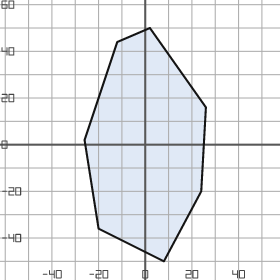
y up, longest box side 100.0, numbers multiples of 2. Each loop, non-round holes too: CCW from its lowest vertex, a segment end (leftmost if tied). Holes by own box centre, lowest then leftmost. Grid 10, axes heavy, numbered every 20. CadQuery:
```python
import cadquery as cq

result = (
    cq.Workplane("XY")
    .moveTo(8.0, -50.0)
    .lineTo(24.0, -20.0)
    .lineTo(26.0, 16.0)
    .lineTo(2.0, 50.0)
    .lineTo(-12.0, 44.0)
    .lineTo(-26.0, 2.0)
    .lineTo(-20.0, -36.0)
    .close()
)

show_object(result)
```